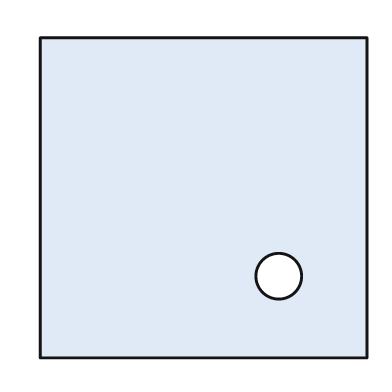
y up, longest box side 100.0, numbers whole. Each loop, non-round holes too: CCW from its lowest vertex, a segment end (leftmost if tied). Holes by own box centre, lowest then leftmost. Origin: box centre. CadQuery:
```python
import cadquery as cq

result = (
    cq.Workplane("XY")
    .moveTo(-50.0, -49.0)
    .lineTo(50.0, -49.0)
    .lineTo(50.0, 49.0)
    .lineTo(-50.0, 49.0)
    .close()
    .moveTo(23.0, -24.0)
    .circle(7.0)
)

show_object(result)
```